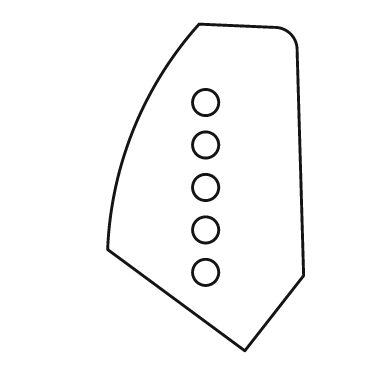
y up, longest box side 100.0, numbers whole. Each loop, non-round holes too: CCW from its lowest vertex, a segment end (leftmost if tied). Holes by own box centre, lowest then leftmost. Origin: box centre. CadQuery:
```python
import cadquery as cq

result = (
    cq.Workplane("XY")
    .moveTo(12.0, -50.0)
    .lineTo(30.0, -27.0)
    .lineTo(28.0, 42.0)
    .threePointArc((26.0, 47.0), (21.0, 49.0))
    .lineTo(-2.0, 50.0)
    .threePointArc((-22.0, 18.0), (-30.0, -19.0))
    .close()
    .moveTo(0.0, -26.0)
    .circle(4.0)
    .moveTo(0.0, -13.0)
    .circle(4.0)
    .moveTo(0.0, 0.0)
    .circle(4.0)
    .moveTo(0.0, 13.0)
    .circle(4.0)
    .moveTo(0.0, 26.0)
    .circle(4.0)
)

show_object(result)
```